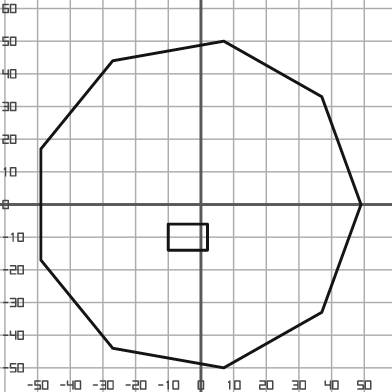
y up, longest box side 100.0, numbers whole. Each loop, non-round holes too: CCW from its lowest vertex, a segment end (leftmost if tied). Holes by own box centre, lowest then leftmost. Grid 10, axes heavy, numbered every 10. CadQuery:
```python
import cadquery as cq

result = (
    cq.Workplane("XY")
    .moveTo(7.0, -50.0)
    .lineTo(37.0, -33.0)
    .lineTo(49.0, 0.0)
    .lineTo(37.0, 33.0)
    .lineTo(7.0, 50.0)
    .lineTo(-27.0, 44.0)
    .lineTo(-49.0, 17.0)
    .lineTo(-49.0, -17.0)
    .lineTo(-27.0, -44.0)
    .close()
    .moveTo(-10.0, -14.0)
    .lineTo(2.0, -14.0)
    .lineTo(2.0, -6.0)
    .lineTo(-10.0, -6.0)
    .close()
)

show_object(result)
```